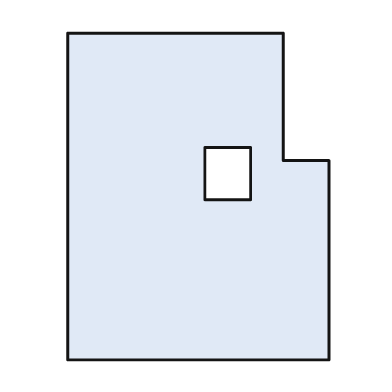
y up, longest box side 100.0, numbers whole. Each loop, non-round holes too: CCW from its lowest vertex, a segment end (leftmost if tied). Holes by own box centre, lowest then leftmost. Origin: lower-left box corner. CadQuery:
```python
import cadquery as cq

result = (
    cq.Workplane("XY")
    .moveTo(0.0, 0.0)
    .lineTo(80.0, 0.0)
    .lineTo(80.0, 61.0)
    .lineTo(66.0, 61.0)
    .lineTo(66.0, 100.0)
    .lineTo(0.0, 100.0)
    .close()
    .moveTo(42.0, 49.0)
    .lineTo(56.0, 49.0)
    .lineTo(56.0, 65.0)
    .lineTo(42.0, 65.0)
    .close()
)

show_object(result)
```